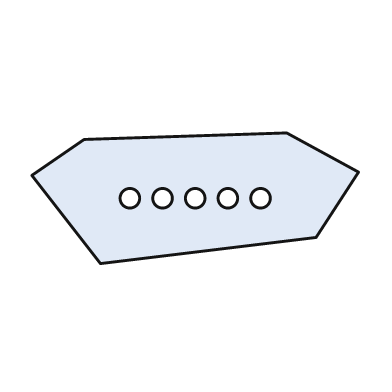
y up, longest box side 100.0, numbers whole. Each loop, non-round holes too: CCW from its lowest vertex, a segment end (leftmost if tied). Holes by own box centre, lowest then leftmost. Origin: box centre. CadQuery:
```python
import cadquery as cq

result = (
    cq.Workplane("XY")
    .moveTo(-29.0, -20.0)
    .lineTo(37.0, -12.0)
    .lineTo(50.0, 8.0)
    .lineTo(28.0, 20.0)
    .lineTo(-34.0, 18.0)
    .lineTo(-50.0, 7.0)
    .close()
    .moveTo(-20.0, 0.0)
    .circle(3.0)
    .moveTo(-10.0, 0.0)
    .circle(3.0)
    .moveTo(0.0, 0.0)
    .circle(3.0)
    .moveTo(10.0, 0.0)
    .circle(3.0)
    .moveTo(20.0, 0.0)
    .circle(3.0)
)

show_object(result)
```